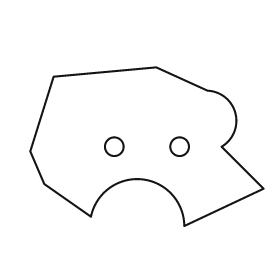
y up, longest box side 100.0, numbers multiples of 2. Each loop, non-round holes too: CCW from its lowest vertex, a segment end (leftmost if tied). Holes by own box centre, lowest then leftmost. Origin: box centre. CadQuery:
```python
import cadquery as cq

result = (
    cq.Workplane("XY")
    .moveTo(16.0, -34.0)
    .lineTo(50.0, -18.0)
    .lineTo(32.0, 0.0)
    .threePointArc((38.0, 14.0), (26.0, 24.0))
    .lineTo(4.0, 34.0)
    .lineTo(-40.0, 30.0)
    .lineTo(-50.0, -2.0)
    .lineTo(-44.0, -16.0)
    .lineTo(-24.0, -30.0)
    .threePointArc((-2.0, -14.0), (16.0, -34.0))
    .close()
    .moveTo(-14.0, 0.0)
    .circle(4.0)
    .moveTo(14.0, 0.0)
    .circle(4.0)
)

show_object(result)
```